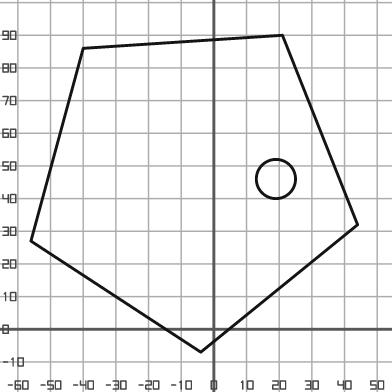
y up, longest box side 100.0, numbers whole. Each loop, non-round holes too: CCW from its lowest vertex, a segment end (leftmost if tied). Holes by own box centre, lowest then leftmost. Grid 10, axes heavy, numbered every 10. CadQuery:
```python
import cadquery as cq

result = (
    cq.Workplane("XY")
    .moveTo(-4.0, -7.0)
    .lineTo(44.0, 32.0)
    .lineTo(21.0, 90.0)
    .lineTo(-40.0, 86.0)
    .lineTo(-56.0, 27.0)
    .close()
    .moveTo(19.0, 46.0)
    .circle(6.0)
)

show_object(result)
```